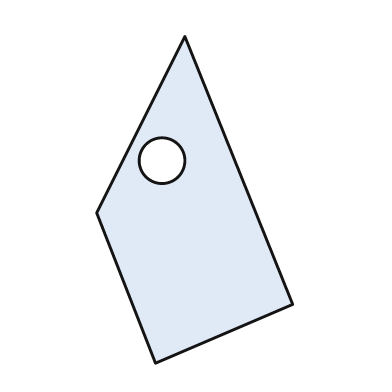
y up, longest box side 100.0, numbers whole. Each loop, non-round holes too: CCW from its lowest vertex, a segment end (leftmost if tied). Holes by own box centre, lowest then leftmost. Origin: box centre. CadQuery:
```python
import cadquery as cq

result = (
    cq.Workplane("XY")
    .moveTo(-12.0, -50.0)
    .lineTo(30.0, -32.0)
    .lineTo(-3.0, 50.0)
    .lineTo(-30.0, -4.0)
    .close()
    .moveTo(-10.0, 12.0)
    .circle(7.0)
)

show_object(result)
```